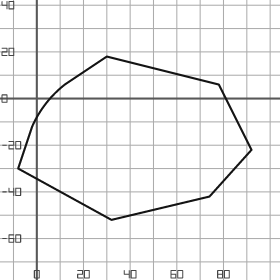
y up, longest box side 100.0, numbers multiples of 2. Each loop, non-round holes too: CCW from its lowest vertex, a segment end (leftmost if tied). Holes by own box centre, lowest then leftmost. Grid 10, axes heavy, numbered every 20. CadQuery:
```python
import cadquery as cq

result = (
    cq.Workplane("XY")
    .moveTo(32.0, -52.0)
    .lineTo(74.0, -42.0)
    .lineTo(92.0, -22.0)
    .lineTo(78.0, 6.0)
    .lineTo(30.0, 18.0)
    .lineTo(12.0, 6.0)
    .threePointArc((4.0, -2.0), (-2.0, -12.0))
    .lineTo(-8.0, -30.0)
    .close()
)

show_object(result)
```